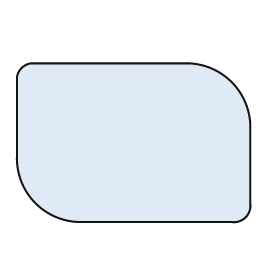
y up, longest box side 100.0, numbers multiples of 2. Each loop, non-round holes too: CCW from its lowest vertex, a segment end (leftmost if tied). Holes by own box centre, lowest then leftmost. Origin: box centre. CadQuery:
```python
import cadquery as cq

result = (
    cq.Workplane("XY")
    .moveTo(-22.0, -34.0)
    .lineTo(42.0, -34.0)
    .threePointArc((48.0, -32.0), (50.0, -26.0))
    .lineTo(50.0, 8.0)
    .threePointArc((42.0, 26.0), (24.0, 34.0))
    .lineTo(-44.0, 34.0)
    .threePointArc((-48.0, 32.0), (-50.0, 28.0))
    .lineTo(-50.0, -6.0)
    .threePointArc((-42.0, -26.0), (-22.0, -34.0))
    .close()
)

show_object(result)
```